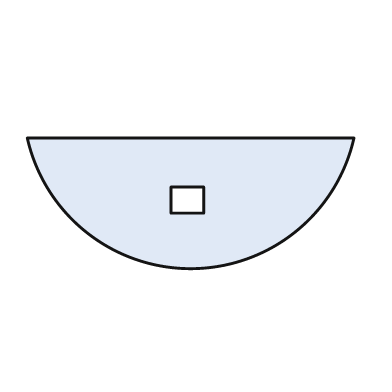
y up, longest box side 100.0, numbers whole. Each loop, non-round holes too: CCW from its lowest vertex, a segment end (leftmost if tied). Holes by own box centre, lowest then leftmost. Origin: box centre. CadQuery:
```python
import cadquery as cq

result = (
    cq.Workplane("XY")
    .moveTo(-50.0, 20.0)
    .threePointArc((0.0, -20.0), (50.0, 20.0))
    .close()
    .moveTo(-6.0, -3.0)
    .lineTo(4.0, -3.0)
    .lineTo(4.0, 5.0)
    .lineTo(-6.0, 5.0)
    .close()
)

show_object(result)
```